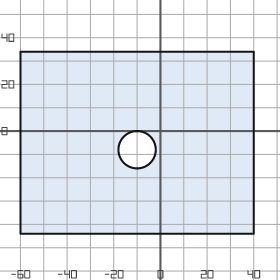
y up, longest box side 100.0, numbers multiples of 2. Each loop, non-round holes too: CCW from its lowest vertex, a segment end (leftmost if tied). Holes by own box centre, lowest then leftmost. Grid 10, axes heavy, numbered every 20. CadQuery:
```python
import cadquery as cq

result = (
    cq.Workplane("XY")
    .moveTo(-60.0, -44.0)
    .lineTo(40.0, -44.0)
    .lineTo(40.0, 34.0)
    .lineTo(-60.0, 34.0)
    .close()
    .moveTo(-10.0, -8.0)
    .circle(8.0)
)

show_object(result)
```